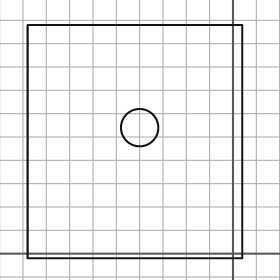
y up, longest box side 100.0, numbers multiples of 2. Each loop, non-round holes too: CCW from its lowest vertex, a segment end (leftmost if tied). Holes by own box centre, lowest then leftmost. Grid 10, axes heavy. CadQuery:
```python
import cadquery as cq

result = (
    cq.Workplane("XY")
    .moveTo(-88.0, -2.0)
    .lineTo(4.0, -2.0)
    .lineTo(4.0, 98.0)
    .lineTo(-88.0, 98.0)
    .close()
    .moveTo(-40.0, 54.0)
    .circle(8.0)
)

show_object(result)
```